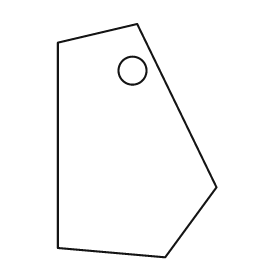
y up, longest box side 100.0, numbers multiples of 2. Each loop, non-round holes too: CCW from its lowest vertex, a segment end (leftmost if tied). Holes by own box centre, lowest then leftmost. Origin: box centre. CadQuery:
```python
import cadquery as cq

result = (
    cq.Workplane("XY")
    .moveTo(12.0, -50.0)
    .lineTo(34.0, -20.0)
    .lineTo(0.0, 50.0)
    .lineTo(-34.0, 42.0)
    .lineTo(-34.0, -46.0)
    .close()
    .moveTo(-2.0, 30.0)
    .circle(6.0)
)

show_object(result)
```